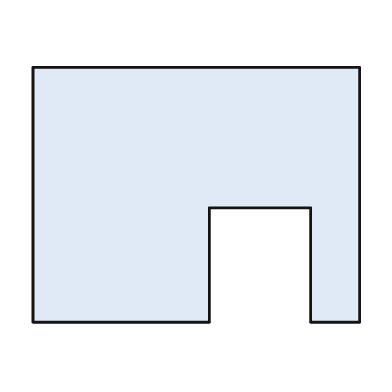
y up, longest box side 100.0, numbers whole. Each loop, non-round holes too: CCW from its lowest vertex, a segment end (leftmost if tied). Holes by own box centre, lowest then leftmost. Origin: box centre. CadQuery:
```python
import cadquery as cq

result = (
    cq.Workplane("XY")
    .moveTo(-50.0, -39.0)
    .lineTo(4.0, -39.0)
    .lineTo(4.0, -4.0)
    .lineTo(35.0, -4.0)
    .lineTo(35.0, -39.0)
    .lineTo(50.0, -39.0)
    .lineTo(50.0, 39.0)
    .lineTo(-50.0, 39.0)
    .close()
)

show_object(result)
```